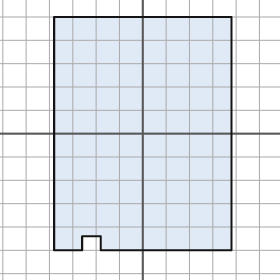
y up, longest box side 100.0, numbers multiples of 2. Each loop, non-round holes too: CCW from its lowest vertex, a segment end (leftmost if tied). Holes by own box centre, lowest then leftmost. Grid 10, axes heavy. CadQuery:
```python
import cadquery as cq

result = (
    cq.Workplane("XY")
    .moveTo(-38.0, -50.0)
    .lineTo(-26.0, -50.0)
    .lineTo(-26.0, -44.0)
    .lineTo(-18.0, -44.0)
    .lineTo(-18.0, -50.0)
    .lineTo(38.0, -50.0)
    .lineTo(38.0, 50.0)
    .lineTo(-38.0, 50.0)
    .close()
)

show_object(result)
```